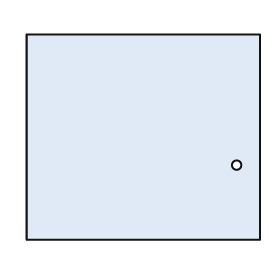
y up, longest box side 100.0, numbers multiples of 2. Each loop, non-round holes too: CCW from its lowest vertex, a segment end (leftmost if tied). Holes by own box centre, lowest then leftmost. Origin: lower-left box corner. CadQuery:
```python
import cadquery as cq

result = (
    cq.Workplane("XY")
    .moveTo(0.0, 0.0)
    .lineTo(100.0, 0.0)
    .lineTo(100.0, 88.0)
    .lineTo(0.0, 88.0)
    .close()
    .moveTo(90.0, 32.0)
    .circle(2.0)
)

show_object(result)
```